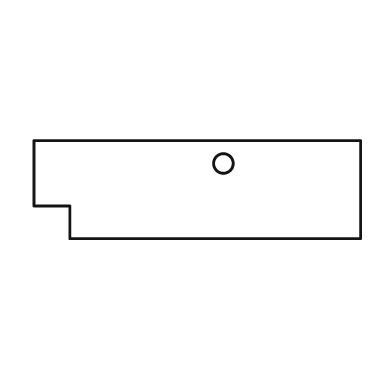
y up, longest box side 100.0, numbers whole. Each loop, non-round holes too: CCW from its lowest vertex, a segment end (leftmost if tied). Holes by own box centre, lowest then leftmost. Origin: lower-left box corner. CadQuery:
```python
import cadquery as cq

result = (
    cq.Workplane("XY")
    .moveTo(11.0, 0.0)
    .lineTo(100.0, 0.0)
    .lineTo(100.0, 30.0)
    .lineTo(0.0, 30.0)
    .lineTo(0.0, 10.0)
    .lineTo(11.0, 10.0)
    .close()
    .moveTo(58.0, 23.0)
    .circle(3.0)
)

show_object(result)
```